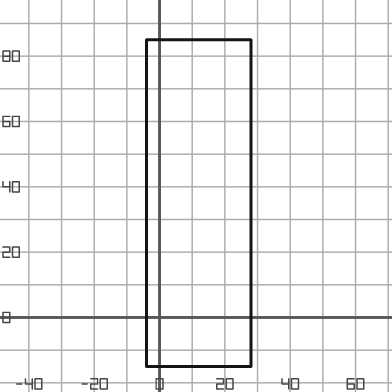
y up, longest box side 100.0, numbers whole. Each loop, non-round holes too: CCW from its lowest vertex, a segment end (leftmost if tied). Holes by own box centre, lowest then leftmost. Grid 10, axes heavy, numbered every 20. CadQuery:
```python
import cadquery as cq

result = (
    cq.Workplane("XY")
    .moveTo(-4.0, -15.0)
    .lineTo(28.0, -15.0)
    .lineTo(28.0, 85.0)
    .lineTo(-4.0, 85.0)
    .close()
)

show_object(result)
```